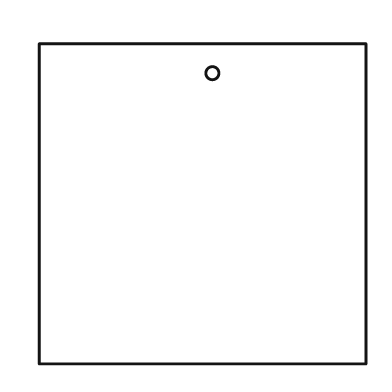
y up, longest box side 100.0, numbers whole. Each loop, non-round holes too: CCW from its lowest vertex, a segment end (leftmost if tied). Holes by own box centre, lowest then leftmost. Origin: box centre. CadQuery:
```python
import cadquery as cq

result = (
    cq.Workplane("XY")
    .moveTo(-50.0, -49.0)
    .lineTo(50.0, -49.0)
    .lineTo(50.0, 49.0)
    .lineTo(-50.0, 49.0)
    .close()
    .moveTo(3.0, 40.0)
    .circle(2.0)
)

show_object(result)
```